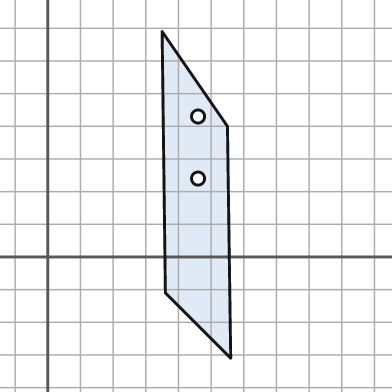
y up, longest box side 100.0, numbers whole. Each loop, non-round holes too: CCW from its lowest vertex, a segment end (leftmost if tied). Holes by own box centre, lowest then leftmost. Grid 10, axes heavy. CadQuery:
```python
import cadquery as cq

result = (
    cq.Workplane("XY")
    .moveTo(56.0, -31.0)
    .lineTo(55.0, 40.0)
    .lineTo(35.0, 69.0)
    .lineTo(36.0, -11.0)
    .close()
    .moveTo(46.0, 24.0)
    .circle(2.0)
    .moveTo(46.0, 43.0)
    .circle(2.0)
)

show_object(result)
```